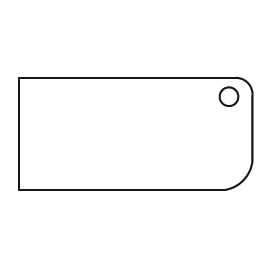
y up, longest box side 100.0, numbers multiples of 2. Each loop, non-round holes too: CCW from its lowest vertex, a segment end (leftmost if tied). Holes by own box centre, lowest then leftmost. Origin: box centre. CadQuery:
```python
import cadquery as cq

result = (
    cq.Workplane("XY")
    .moveTo(-50.0, -24.0)
    .lineTo(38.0, -24.0)
    .threePointArc((46.0, -20.0), (50.0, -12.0))
    .lineTo(50.0, 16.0)
    .threePointArc((48.0, 22.0), (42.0, 24.0))
    .lineTo(-50.0, 24.0)
    .close()
    .moveTo(40.0, 16.0)
    .circle(4.0)
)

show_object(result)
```